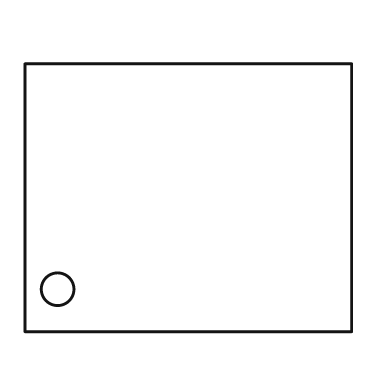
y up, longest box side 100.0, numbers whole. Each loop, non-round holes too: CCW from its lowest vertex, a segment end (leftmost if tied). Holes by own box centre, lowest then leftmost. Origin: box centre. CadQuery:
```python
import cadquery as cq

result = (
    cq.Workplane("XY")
    .moveTo(-50.0, -41.0)
    .lineTo(50.0, -41.0)
    .lineTo(50.0, 41.0)
    .lineTo(-50.0, 41.0)
    .close()
    .moveTo(-40.0, -28.0)
    .circle(5.0)
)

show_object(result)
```